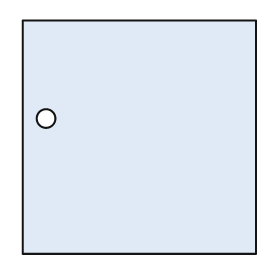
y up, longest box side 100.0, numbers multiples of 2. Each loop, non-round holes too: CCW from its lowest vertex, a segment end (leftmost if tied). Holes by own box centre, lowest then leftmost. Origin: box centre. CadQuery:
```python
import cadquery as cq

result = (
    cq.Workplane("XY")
    .moveTo(-50.0, -50.0)
    .lineTo(50.0, -50.0)
    .lineTo(50.0, 50.0)
    .lineTo(-50.0, 50.0)
    .close()
    .moveTo(-40.0, 8.0)
    .circle(4.0)
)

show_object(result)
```